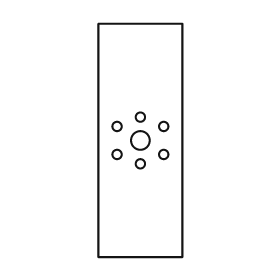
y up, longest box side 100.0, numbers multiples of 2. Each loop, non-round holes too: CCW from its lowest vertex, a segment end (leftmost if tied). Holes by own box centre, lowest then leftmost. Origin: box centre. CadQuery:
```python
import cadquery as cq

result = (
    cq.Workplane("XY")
    .moveTo(-18.0, -50.0)
    .lineTo(18.0, -50.0)
    .lineTo(18.0, 50.0)
    .lineTo(-18.0, 50.0)
    .close()
    .moveTo(0.0, -10.0)
    .circle(2.0)
    .moveTo(-10.0, -6.0)
    .circle(2.0)
    .moveTo(10.0, -6.0)
    .circle(2.0)
    .moveTo(0.0, 0.0)
    .circle(4.0)
    .moveTo(-10.0, 6.0)
    .circle(2.0)
    .moveTo(10.0, 6.0)
    .circle(2.0)
    .moveTo(0.0, 10.0)
    .circle(2.0)
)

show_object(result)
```